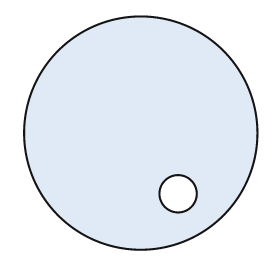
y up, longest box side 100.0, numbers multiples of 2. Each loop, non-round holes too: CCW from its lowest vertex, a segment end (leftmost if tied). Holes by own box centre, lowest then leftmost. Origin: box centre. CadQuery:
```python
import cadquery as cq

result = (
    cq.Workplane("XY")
    .moveTo(0.0, 0.0)
    .circle(50.0)
    .moveTo(16.0, -26.0)
    .circle(8.0)
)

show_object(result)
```